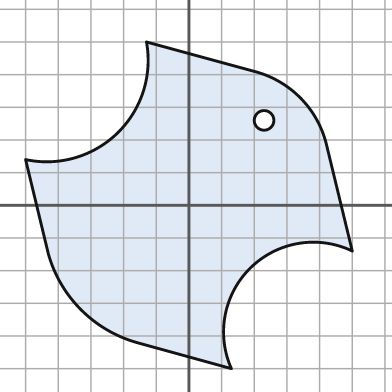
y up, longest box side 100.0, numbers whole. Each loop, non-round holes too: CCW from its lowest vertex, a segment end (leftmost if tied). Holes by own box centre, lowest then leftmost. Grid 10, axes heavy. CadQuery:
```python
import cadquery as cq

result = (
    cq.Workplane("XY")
    .moveTo(13.0, -50.0)
    .threePointArc((19.0, -19.0), (50.0, -14.0))
    .lineTo(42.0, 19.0)
    .threePointArc((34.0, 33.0), (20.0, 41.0))
    .lineTo(-13.0, 50.0)
    .threePointArc((-22.0, 22.0), (-50.0, 14.0))
    .lineTo(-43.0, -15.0)
    .threePointArc((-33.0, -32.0), (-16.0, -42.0))
    .close()
    .moveTo(23.0, 26.0)
    .circle(3.0)
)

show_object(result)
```